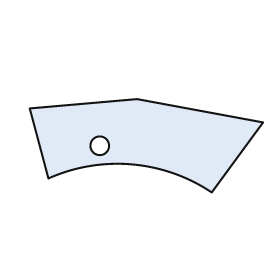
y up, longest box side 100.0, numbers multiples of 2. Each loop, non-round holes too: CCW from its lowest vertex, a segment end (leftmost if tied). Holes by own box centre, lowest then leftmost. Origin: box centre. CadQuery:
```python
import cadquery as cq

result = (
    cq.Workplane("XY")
    .moveTo(28.0, -20.0)
    .lineTo(50.0, 10.0)
    .lineTo(-4.0, 20.0)
    .lineTo(-50.0, 16.0)
    .lineTo(-42.0, -14.0)
    .threePointArc((-6.0, -8.0), (28.0, -20.0))
    .close()
    .moveTo(-20.0, 0.0)
    .circle(4.0)
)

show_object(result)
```